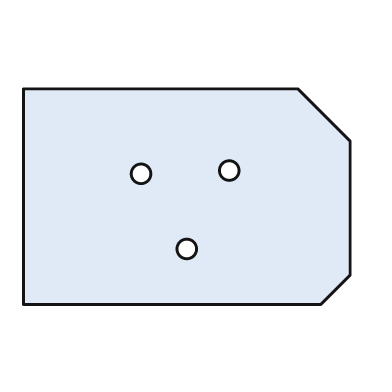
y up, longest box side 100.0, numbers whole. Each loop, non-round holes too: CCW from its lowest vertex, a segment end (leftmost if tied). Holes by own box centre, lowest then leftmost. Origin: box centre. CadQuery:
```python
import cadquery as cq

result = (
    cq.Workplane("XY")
    .moveTo(-50.0, -33.0)
    .lineTo(41.0, -33.0)
    .lineTo(50.0, -24.0)
    .lineTo(50.0, 17.0)
    .lineTo(34.0, 33.0)
    .lineTo(-50.0, 33.0)
    .close()
    .moveTo(0.0, -16.0)
    .circle(3.0)
    .moveTo(-14.0, 7.0)
    .circle(3.0)
    .moveTo(13.0, 8.0)
    .circle(3.0)
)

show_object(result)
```